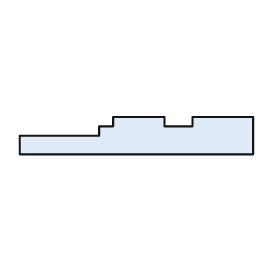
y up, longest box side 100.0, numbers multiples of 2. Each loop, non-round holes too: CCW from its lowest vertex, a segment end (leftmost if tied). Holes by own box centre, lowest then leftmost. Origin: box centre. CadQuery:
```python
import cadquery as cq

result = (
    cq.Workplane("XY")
    .moveTo(-50.0, -8.0)
    .lineTo(50.0, -8.0)
    .lineTo(50.0, 8.0)
    .lineTo(24.0, 8.0)
    .lineTo(24.0, 4.0)
    .lineTo(12.0, 4.0)
    .lineTo(12.0, 8.0)
    .lineTo(-10.0, 8.0)
    .lineTo(-10.0, 4.0)
    .lineTo(-16.0, 4.0)
    .lineTo(-16.0, 0.0)
    .lineTo(-50.0, 0.0)
    .close()
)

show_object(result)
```